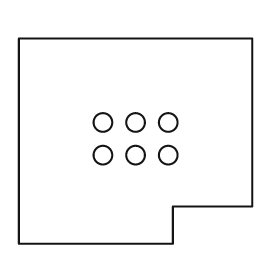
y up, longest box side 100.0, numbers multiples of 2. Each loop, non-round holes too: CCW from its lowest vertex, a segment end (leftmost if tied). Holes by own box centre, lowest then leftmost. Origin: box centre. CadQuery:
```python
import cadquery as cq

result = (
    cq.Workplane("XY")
    .moveTo(-50.0, -44.0)
    .lineTo(16.0, -44.0)
    .lineTo(16.0, -28.0)
    .lineTo(50.0, -28.0)
    .lineTo(50.0, 44.0)
    .lineTo(-50.0, 44.0)
    .close()
    .moveTo(-14.0, -6.0)
    .circle(4.0)
    .moveTo(0.0, -6.0)
    .circle(4.0)
    .moveTo(14.0, -6.0)
    .circle(4.0)
    .moveTo(-14.0, 8.0)
    .circle(4.0)
    .moveTo(0.0, 8.0)
    .circle(4.0)
    .moveTo(14.0, 8.0)
    .circle(4.0)
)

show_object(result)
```